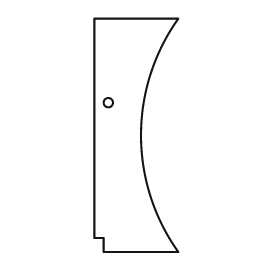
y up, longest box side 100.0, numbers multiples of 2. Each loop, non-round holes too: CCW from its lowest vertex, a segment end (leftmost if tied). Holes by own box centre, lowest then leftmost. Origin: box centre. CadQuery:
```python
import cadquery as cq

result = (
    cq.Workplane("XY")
    .moveTo(-14.0, -50.0)
    .lineTo(18.0, -50.0)
    .threePointArc((2.0, 0.0), (18.0, 50.0))
    .lineTo(-18.0, 50.0)
    .lineTo(-18.0, -44.0)
    .lineTo(-14.0, -44.0)
    .close()
    .moveTo(-12.0, 14.0)
    .circle(2.0)
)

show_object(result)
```